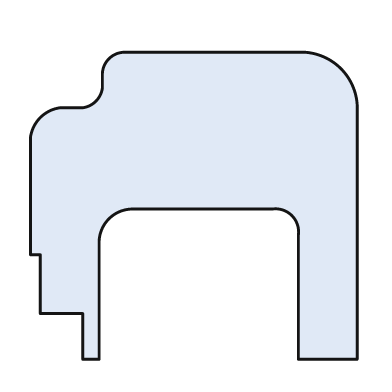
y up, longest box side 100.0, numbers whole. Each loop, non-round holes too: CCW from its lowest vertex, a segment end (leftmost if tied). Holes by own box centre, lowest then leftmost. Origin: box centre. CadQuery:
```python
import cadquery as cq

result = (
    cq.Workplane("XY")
    .moveTo(-34.0, -47.0)
    .lineTo(-29.0, -47.0)
    .lineTo(-29.0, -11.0)
    .threePointArc((-26.0, -4.0), (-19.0, -1.0))
    .lineTo(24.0, -1.0)
    .threePointArc((30.0, -3.0), (32.0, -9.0))
    .lineTo(32.0, -47.0)
    .lineTo(50.0, -47.0)
    .lineTo(50.0, 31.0)
    .threePointArc((45.0, 42.0), (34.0, 47.0))
    .lineTo(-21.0, 47.0)
    .threePointArc((-26.0, 45.0), (-28.0, 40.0))
    .lineTo(-28.0, 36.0)
    .threePointArc((-30.0, 32.0), (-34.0, 30.0))
    .lineTo(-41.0, 30.0)
    .threePointArc((-47.0, 27.0), (-50.0, 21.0))
    .lineTo(-50.0, -15.0)
    .lineTo(-47.0, -15.0)
    .lineTo(-47.0, -33.0)
    .lineTo(-34.0, -33.0)
    .close()
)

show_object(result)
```